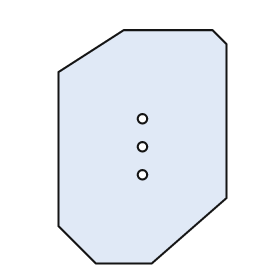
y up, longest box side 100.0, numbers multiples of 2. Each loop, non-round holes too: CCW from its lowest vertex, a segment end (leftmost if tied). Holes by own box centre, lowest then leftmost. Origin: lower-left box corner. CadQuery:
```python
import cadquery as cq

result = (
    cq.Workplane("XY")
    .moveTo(16.0, 0.0)
    .lineTo(40.0, 0.0)
    .lineTo(72.0, 28.0)
    .lineTo(72.0, 94.0)
    .lineTo(66.0, 100.0)
    .lineTo(28.0, 100.0)
    .lineTo(0.0, 82.0)
    .lineTo(0.0, 16.0)
    .close()
    .moveTo(36.0, 38.0)
    .circle(2.0)
    .moveTo(36.0, 50.0)
    .circle(2.0)
    .moveTo(36.0, 62.0)
    .circle(2.0)
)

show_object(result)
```